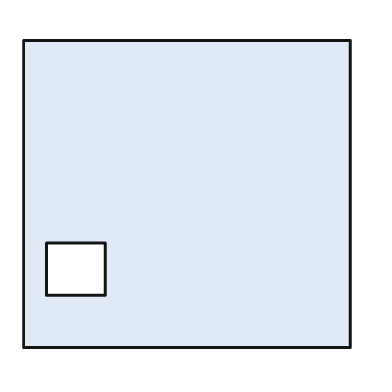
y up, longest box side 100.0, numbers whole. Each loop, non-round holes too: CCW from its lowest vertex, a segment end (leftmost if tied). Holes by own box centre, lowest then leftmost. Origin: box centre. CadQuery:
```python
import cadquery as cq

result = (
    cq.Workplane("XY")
    .moveTo(-50.0, -47.0)
    .lineTo(50.0, -47.0)
    .lineTo(50.0, 47.0)
    .lineTo(-50.0, 47.0)
    .close()
    .moveTo(-43.0, -31.0)
    .lineTo(-25.0, -31.0)
    .lineTo(-25.0, -15.0)
    .lineTo(-43.0, -15.0)
    .close()
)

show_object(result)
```